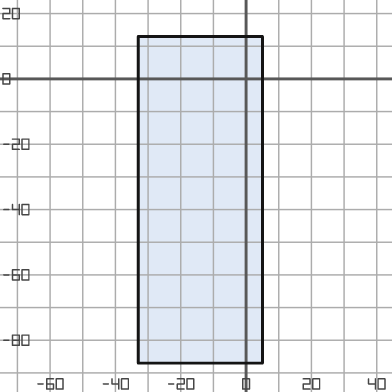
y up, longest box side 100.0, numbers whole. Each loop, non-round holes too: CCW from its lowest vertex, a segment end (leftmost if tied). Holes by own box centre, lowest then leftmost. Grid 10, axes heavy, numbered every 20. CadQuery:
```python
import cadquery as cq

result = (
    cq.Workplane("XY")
    .moveTo(-33.0, -87.0)
    .lineTo(5.0, -87.0)
    .lineTo(5.0, 13.0)
    .lineTo(-33.0, 13.0)
    .close()
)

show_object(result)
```